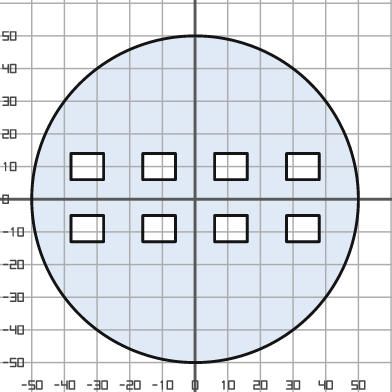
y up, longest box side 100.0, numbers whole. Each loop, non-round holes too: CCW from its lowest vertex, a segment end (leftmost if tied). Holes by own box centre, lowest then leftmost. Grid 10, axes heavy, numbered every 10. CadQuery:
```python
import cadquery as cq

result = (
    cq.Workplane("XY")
    .moveTo(0.0, 0.0)
    .circle(50.0)
    .moveTo(-38.0, -13.0)
    .lineTo(-28.0, -13.0)
    .lineTo(-28.0, -5.0)
    .lineTo(-38.0, -5.0)
    .close()
    .moveTo(-16.0, -13.0)
    .lineTo(-6.0, -13.0)
    .lineTo(-6.0, -5.0)
    .lineTo(-16.0, -5.0)
    .close()
    .moveTo(6.0, -13.0)
    .lineTo(16.0, -13.0)
    .lineTo(16.0, -5.0)
    .lineTo(6.0, -5.0)
    .close()
    .moveTo(28.0, -13.0)
    .lineTo(38.0, -13.0)
    .lineTo(38.0, -5.0)
    .lineTo(28.0, -5.0)
    .close()
    .moveTo(-38.0, 6.0)
    .lineTo(-28.0, 6.0)
    .lineTo(-28.0, 14.0)
    .lineTo(-38.0, 14.0)
    .close()
    .moveTo(-16.0, 6.0)
    .lineTo(-6.0, 6.0)
    .lineTo(-6.0, 14.0)
    .lineTo(-16.0, 14.0)
    .close()
    .moveTo(6.0, 6.0)
    .lineTo(16.0, 6.0)
    .lineTo(16.0, 14.0)
    .lineTo(6.0, 14.0)
    .close()
    .moveTo(28.0, 6.0)
    .lineTo(38.0, 6.0)
    .lineTo(38.0, 14.0)
    .lineTo(28.0, 14.0)
    .close()
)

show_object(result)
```